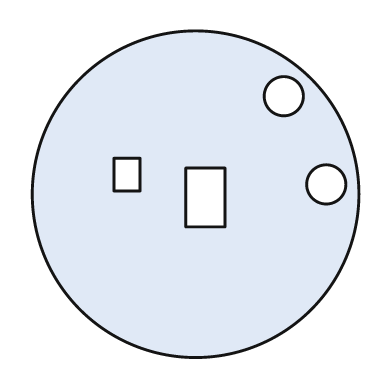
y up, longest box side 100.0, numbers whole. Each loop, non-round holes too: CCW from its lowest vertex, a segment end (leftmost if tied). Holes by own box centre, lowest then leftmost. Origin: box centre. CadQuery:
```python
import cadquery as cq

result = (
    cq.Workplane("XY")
    .moveTo(0.0, 0.0)
    .circle(50.0)
    .moveTo(-3.0, -10.0)
    .lineTo(9.0, -10.0)
    .lineTo(9.0, 8.0)
    .lineTo(-3.0, 8.0)
    .close()
    .moveTo(40.0, 3.0)
    .circle(6.0)
    .moveTo(-25.0, 1.0)
    .lineTo(-17.0, 1.0)
    .lineTo(-17.0, 11.0)
    .lineTo(-25.0, 11.0)
    .close()
    .moveTo(27.0, 30.0)
    .circle(6.0)
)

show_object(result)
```